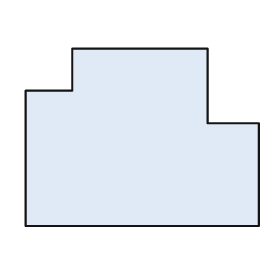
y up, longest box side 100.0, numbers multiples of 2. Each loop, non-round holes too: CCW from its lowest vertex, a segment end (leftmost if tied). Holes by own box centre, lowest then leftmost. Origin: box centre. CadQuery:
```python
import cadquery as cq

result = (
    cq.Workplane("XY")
    .moveTo(-50.0, -38.0)
    .lineTo(50.0, -38.0)
    .lineTo(50.0, 6.0)
    .lineTo(28.0, 6.0)
    .lineTo(28.0, 38.0)
    .lineTo(-30.0, 38.0)
    .lineTo(-30.0, 20.0)
    .lineTo(-50.0, 20.0)
    .close()
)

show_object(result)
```